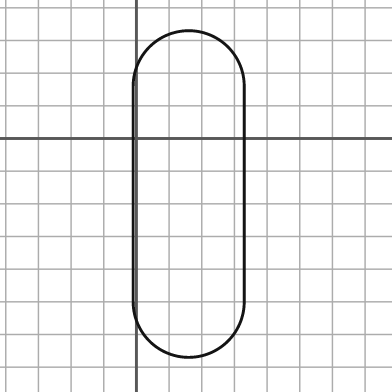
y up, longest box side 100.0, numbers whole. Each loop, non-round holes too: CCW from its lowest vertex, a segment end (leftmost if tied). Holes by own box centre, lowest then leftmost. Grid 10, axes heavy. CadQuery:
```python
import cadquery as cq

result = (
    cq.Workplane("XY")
    .moveTo(-1.0, -50.0)
    .threePointArc((16.0, -67.0), (33.0, -50.0))
    .lineTo(33.0, 16.0)
    .threePointArc((16.0, 33.0), (-1.0, 16.0))
    .close()
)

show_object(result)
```